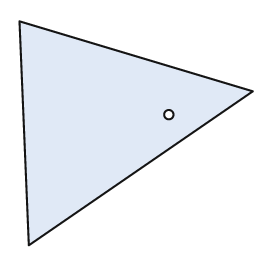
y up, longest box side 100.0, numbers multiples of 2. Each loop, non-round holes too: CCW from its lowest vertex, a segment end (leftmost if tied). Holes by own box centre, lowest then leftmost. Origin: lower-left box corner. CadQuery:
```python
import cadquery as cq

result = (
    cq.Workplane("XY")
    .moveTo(4.0, 0.0)
    .lineTo(100.0, 66.0)
    .lineTo(0.0, 96.0)
    .close()
    .moveTo(64.0, 56.0)
    .circle(2.0)
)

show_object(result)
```